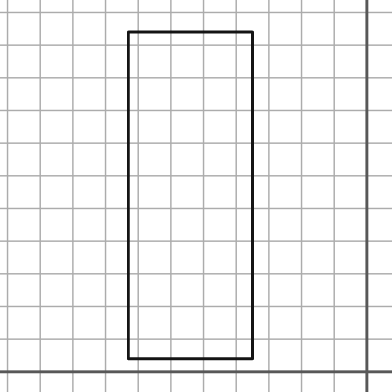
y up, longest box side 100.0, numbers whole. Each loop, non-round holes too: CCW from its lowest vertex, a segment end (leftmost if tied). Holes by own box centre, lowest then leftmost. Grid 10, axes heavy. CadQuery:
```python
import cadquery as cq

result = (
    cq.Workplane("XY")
    .moveTo(-73.0, 4.0)
    .lineTo(-35.0, 4.0)
    .lineTo(-35.0, 104.0)
    .lineTo(-73.0, 104.0)
    .close()
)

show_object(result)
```